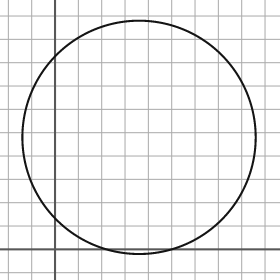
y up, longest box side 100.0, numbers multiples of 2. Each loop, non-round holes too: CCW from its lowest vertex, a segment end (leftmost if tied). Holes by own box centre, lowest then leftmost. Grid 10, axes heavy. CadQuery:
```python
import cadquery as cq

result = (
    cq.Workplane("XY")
    .moveTo(36.0, 48.0)
    .circle(50.0)
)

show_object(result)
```